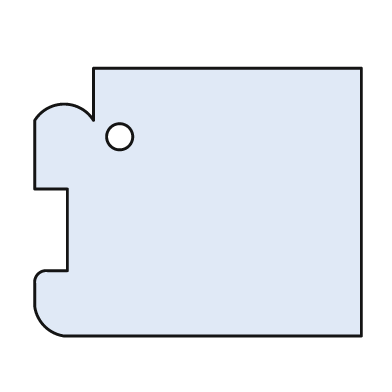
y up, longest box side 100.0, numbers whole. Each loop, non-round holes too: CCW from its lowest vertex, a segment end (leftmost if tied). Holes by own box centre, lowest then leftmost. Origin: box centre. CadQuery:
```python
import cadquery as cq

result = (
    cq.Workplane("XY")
    .moveTo(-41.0, -41.0)
    .lineTo(50.0, -41.0)
    .lineTo(50.0, 41.0)
    .lineTo(-32.0, 41.0)
    .lineTo(-32.0, 25.0)
    .threePointArc((-41.0, 30.0), (-50.0, 25.0))
    .lineTo(-50.0, 4.0)
    .lineTo(-40.0, 4.0)
    .lineTo(-40.0, -21.0)
    .lineTo(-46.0, -21.0)
    .threePointArc((-49.0, -22.0), (-50.0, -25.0))
    .lineTo(-50.0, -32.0)
    .threePointArc((-47.0, -38.0), (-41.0, -41.0))
    .close()
    .moveTo(-24.0, 20.0)
    .circle(4.0)
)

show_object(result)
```